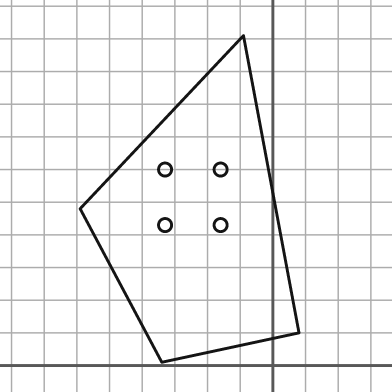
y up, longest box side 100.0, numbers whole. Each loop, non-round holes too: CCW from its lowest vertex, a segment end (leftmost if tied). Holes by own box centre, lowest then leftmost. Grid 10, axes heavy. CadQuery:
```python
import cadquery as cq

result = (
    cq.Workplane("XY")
    .moveTo(-34.0, 1.0)
    .lineTo(8.0, 10.0)
    .lineTo(-9.0, 101.0)
    .lineTo(-59.0, 48.0)
    .close()
    .moveTo(-33.0, 43.0)
    .circle(2.0)
    .moveTo(-16.0, 43.0)
    .circle(2.0)
    .moveTo(-33.0, 60.0)
    .circle(2.0)
    .moveTo(-16.0, 60.0)
    .circle(2.0)
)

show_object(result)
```